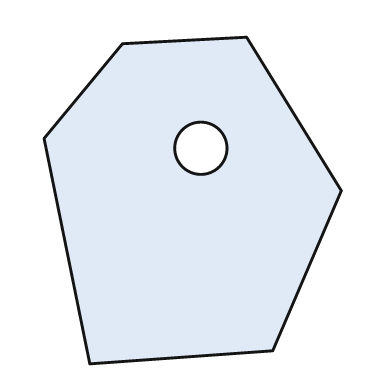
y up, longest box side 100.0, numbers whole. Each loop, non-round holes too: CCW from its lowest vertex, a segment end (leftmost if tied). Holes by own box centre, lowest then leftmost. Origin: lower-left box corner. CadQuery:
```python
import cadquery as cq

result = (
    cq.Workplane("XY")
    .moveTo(14.0, 0.0)
    .lineTo(70.0, 4.0)
    .lineTo(91.0, 53.0)
    .lineTo(62.0, 100.0)
    .lineTo(24.0, 98.0)
    .lineTo(0.0, 69.0)
    .close()
    .moveTo(48.0, 66.0)
    .circle(8.0)
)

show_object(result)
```